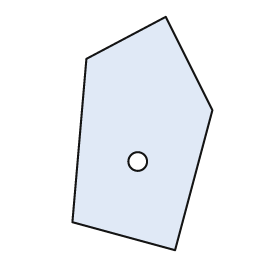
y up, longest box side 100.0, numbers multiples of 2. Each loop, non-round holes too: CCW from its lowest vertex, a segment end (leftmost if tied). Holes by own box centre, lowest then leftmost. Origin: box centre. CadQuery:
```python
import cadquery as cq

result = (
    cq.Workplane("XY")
    .moveTo(14.0, -50.0)
    .lineTo(30.0, 10.0)
    .lineTo(10.0, 50.0)
    .lineTo(-24.0, 32.0)
    .lineTo(-30.0, -38.0)
    .close()
    .moveTo(-2.0, -12.0)
    .circle(4.0)
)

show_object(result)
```